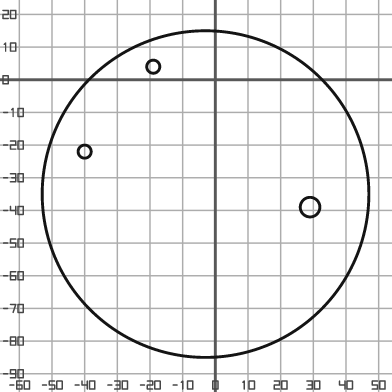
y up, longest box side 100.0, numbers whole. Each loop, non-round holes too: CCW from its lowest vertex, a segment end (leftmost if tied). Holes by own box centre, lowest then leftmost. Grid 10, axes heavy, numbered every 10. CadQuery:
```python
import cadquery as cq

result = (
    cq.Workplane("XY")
    .moveTo(-3.0, -35.0)
    .circle(50.0)
    .moveTo(29.0, -39.0)
    .circle(3.0)
    .moveTo(-40.0, -22.0)
    .circle(2.0)
    .moveTo(-19.0, 4.0)
    .circle(2.0)
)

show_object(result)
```